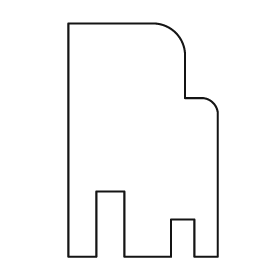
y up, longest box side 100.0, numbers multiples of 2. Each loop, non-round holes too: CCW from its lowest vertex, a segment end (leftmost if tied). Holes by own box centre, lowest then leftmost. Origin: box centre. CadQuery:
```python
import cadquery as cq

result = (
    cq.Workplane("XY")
    .moveTo(-32.0, -50.0)
    .lineTo(-20.0, -50.0)
    .lineTo(-20.0, -22.0)
    .lineTo(-8.0, -22.0)
    .lineTo(-8.0, -50.0)
    .lineTo(12.0, -50.0)
    .lineTo(12.0, -34.0)
    .lineTo(22.0, -34.0)
    .lineTo(22.0, -50.0)
    .lineTo(32.0, -50.0)
    .lineTo(32.0, 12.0)
    .threePointArc((30.0, 16.0), (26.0, 18.0))
    .lineTo(18.0, 18.0)
    .lineTo(18.0, 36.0)
    .threePointArc((14.0, 46.0), (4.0, 50.0))
    .lineTo(-32.0, 50.0)
    .close()
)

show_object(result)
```